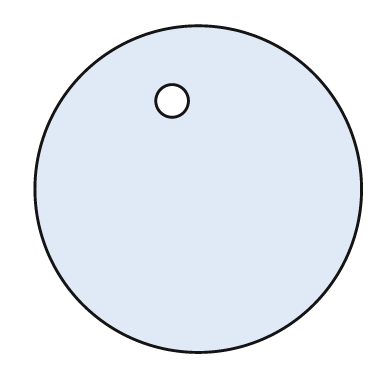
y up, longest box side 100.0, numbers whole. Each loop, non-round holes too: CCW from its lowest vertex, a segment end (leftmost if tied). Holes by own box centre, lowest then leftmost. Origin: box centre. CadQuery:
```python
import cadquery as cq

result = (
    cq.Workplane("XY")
    .moveTo(0.0, 0.0)
    .circle(50.0)
    .moveTo(-8.0, 27.0)
    .circle(5.0)
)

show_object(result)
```